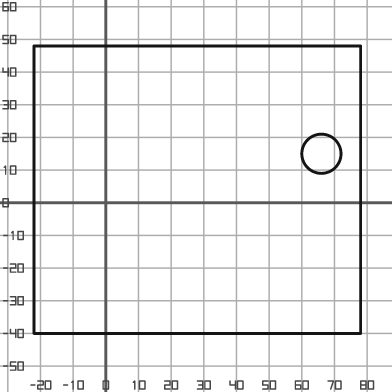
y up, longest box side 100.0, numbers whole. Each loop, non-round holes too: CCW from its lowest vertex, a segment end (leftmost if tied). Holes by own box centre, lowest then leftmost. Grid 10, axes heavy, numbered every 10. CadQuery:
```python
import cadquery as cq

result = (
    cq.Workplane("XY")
    .moveTo(-22.0, -40.0)
    .lineTo(78.0, -40.0)
    .lineTo(78.0, 48.0)
    .lineTo(-22.0, 48.0)
    .close()
    .moveTo(66.0, 15.0)
    .circle(6.0)
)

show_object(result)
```